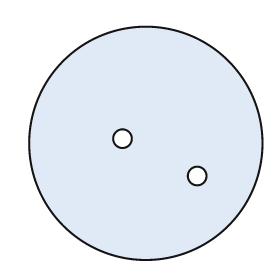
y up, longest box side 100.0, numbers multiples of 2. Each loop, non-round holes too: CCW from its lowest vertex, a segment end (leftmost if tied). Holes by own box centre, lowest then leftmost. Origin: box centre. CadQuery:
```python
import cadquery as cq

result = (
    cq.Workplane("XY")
    .moveTo(0.0, 0.0)
    .circle(50.0)
    .moveTo(22.0, -14.0)
    .circle(4.0)
    .moveTo(-10.0, 2.0)
    .circle(4.0)
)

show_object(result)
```